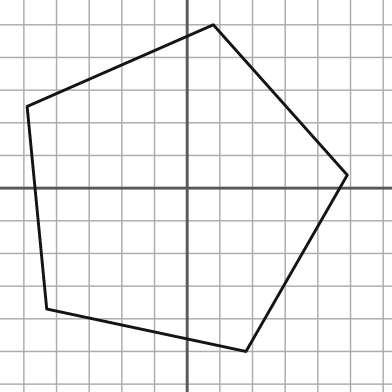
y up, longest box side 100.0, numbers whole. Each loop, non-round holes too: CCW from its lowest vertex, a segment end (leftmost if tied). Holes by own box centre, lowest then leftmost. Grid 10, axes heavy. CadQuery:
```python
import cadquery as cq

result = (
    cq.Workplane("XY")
    .moveTo(18.0, -50.0)
    .lineTo(49.0, 4.0)
    .lineTo(8.0, 50.0)
    .lineTo(-49.0, 25.0)
    .lineTo(-43.0, -37.0)
    .close()
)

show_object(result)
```